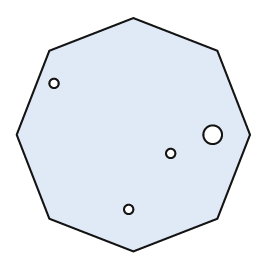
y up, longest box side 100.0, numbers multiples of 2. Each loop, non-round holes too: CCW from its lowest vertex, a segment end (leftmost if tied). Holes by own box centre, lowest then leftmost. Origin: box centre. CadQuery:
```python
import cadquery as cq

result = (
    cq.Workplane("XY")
    .moveTo(0.0, -50.0)
    .lineTo(36.0, -36.0)
    .lineTo(50.0, 0.0)
    .lineTo(36.0, 36.0)
    .lineTo(0.0, 50.0)
    .lineTo(-36.0, 36.0)
    .lineTo(-50.0, 0.0)
    .lineTo(-36.0, -36.0)
    .close()
    .moveTo(-2.0, -32.0)
    .circle(2.0)
    .moveTo(16.0, -8.0)
    .circle(2.0)
    .moveTo(34.0, 0.0)
    .circle(4.0)
    .moveTo(-34.0, 22.0)
    .circle(2.0)
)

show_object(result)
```